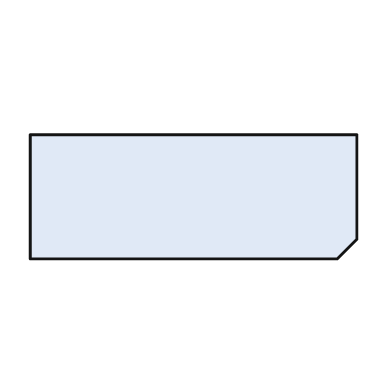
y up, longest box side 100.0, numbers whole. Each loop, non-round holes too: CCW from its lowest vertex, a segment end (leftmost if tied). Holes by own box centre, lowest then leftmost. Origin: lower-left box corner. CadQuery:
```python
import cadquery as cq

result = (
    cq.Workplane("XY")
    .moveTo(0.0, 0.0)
    .lineTo(94.0, 0.0)
    .lineTo(100.0, 6.0)
    .lineTo(100.0, 38.0)
    .lineTo(0.0, 38.0)
    .close()
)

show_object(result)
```